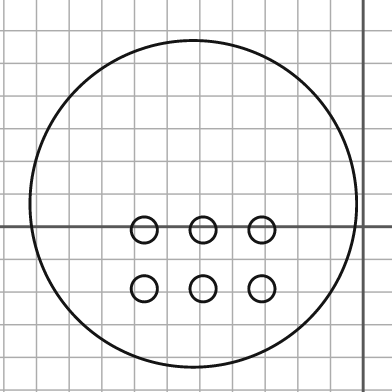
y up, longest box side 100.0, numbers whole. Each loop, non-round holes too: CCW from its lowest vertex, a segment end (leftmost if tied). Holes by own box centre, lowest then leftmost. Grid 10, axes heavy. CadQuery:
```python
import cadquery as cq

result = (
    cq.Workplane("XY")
    .moveTo(-52.0, 7.0)
    .circle(50.0)
    .moveTo(-67.0, -19.0)
    .circle(4.0)
    .moveTo(-49.0, -19.0)
    .circle(4.0)
    .moveTo(-31.0, -19.0)
    .circle(4.0)
    .moveTo(-67.0, -1.0)
    .circle(4.0)
    .moveTo(-49.0, -1.0)
    .circle(4.0)
    .moveTo(-31.0, -1.0)
    .circle(4.0)
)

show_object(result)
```